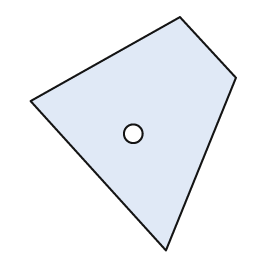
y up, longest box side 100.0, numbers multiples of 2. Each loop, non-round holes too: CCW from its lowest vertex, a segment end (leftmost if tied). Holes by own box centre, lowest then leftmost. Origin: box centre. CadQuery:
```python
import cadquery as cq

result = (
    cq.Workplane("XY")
    .moveTo(14.0, -50.0)
    .lineTo(44.0, 24.0)
    .lineTo(20.0, 50.0)
    .lineTo(-44.0, 14.0)
    .close()
    .moveTo(0.0, 0.0)
    .circle(4.0)
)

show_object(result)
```